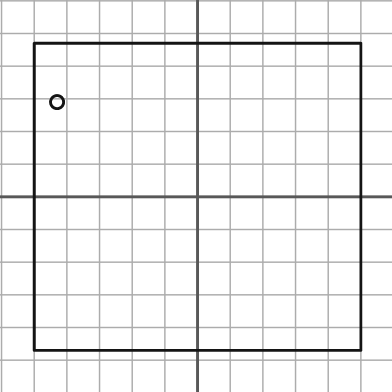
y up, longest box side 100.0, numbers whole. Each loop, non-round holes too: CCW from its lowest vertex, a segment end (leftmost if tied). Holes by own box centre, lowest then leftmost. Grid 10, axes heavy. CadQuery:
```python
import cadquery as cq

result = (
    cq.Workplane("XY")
    .moveTo(-50.0, -47.0)
    .lineTo(50.0, -47.0)
    .lineTo(50.0, 47.0)
    .lineTo(-50.0, 47.0)
    .close()
    .moveTo(-43.0, 29.0)
    .circle(2.0)
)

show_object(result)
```